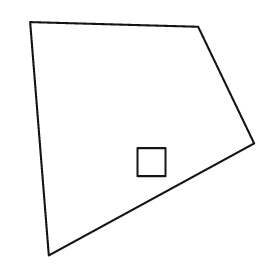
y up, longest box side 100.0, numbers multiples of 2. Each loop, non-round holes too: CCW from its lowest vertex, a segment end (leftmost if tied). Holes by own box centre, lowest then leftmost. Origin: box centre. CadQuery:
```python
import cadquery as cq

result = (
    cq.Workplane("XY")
    .moveTo(-40.0, -50.0)
    .lineTo(48.0, -2.0)
    .lineTo(24.0, 48.0)
    .lineTo(-48.0, 50.0)
    .close()
    .moveTo(-2.0, -16.0)
    .lineTo(10.0, -16.0)
    .lineTo(10.0, -4.0)
    .lineTo(-2.0, -4.0)
    .close()
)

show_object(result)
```